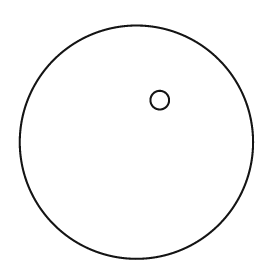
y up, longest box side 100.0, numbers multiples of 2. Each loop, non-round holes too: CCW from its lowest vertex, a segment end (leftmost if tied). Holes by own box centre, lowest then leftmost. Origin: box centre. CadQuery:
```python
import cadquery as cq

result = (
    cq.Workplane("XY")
    .moveTo(0.0, 0.0)
    .circle(50.0)
    .moveTo(10.0, 18.0)
    .circle(4.0)
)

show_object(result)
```